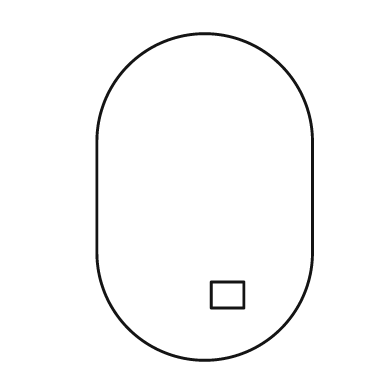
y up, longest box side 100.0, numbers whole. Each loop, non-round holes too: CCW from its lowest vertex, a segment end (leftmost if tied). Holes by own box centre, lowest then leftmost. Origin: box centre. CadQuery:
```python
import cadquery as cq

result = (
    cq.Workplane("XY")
    .moveTo(-33.0, -17.0)
    .threePointArc((0.0, -50.0), (33.0, -17.0))
    .lineTo(33.0, 17.0)
    .threePointArc((0.0, 50.0), (-33.0, 17.0))
    .close()
    .moveTo(2.0, -34.0)
    .lineTo(12.0, -34.0)
    .lineTo(12.0, -26.0)
    .lineTo(2.0, -26.0)
    .close()
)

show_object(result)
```